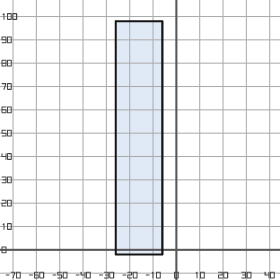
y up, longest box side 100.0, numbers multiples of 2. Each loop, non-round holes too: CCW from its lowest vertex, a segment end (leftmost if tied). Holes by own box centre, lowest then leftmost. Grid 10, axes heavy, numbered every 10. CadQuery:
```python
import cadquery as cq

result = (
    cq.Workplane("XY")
    .moveTo(-26.0, -2.0)
    .lineTo(-6.0, -2.0)
    .lineTo(-6.0, 98.0)
    .lineTo(-26.0, 98.0)
    .close()
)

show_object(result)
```